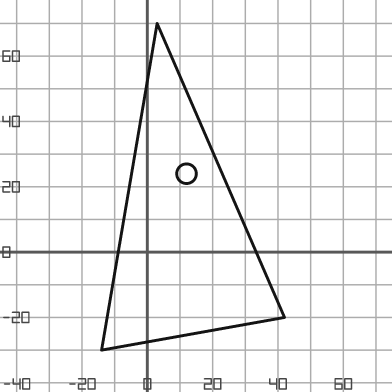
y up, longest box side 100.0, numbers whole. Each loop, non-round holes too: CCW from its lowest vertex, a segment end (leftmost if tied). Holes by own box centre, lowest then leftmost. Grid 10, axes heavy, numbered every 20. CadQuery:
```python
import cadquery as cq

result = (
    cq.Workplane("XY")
    .moveTo(-14.0, -30.0)
    .lineTo(42.0, -20.0)
    .lineTo(3.0, 70.0)
    .close()
    .moveTo(12.0, 24.0)
    .circle(3.0)
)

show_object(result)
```